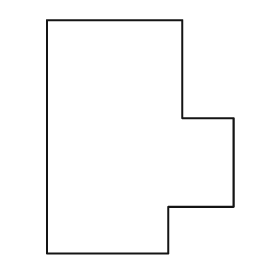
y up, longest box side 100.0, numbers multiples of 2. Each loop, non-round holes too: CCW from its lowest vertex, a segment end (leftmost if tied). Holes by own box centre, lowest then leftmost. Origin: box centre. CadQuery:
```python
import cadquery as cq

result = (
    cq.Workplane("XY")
    .moveTo(-40.0, -50.0)
    .lineTo(12.0, -50.0)
    .lineTo(12.0, -30.0)
    .lineTo(40.0, -30.0)
    .lineTo(40.0, 8.0)
    .lineTo(18.0, 8.0)
    .lineTo(18.0, 50.0)
    .lineTo(-40.0, 50.0)
    .close()
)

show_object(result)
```